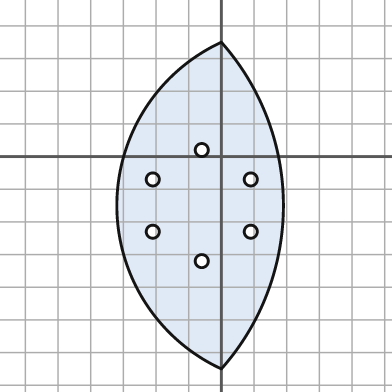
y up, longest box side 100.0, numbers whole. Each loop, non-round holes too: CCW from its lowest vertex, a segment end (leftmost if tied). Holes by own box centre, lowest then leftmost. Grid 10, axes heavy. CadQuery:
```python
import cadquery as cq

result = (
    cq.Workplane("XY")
    .moveTo(0.0, -65.0)
    .threePointArc((19.0, -15.0), (0.0, 35.0))
    .threePointArc((-32.0, -15.0), (0.0, -65.0))
    .close()
    .moveTo(-6.0, -32.0)
    .circle(2.0)
    .moveTo(-21.0, -23.0)
    .circle(2.0)
    .moveTo(9.0, -23.0)
    .circle(2.0)
    .moveTo(-21.0, -7.0)
    .circle(2.0)
    .moveTo(9.0, -7.0)
    .circle(2.0)
    .moveTo(-6.0, 2.0)
    .circle(2.0)
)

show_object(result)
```